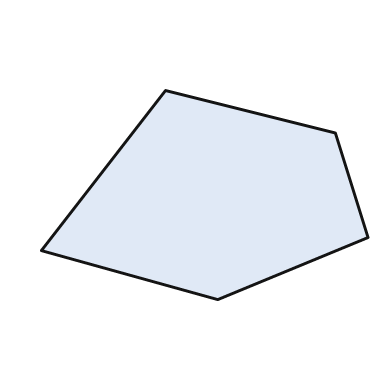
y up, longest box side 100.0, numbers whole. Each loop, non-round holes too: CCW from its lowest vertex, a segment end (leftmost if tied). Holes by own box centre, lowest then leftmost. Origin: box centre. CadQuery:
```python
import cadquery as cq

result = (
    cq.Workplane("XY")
    .moveTo(4.0, -32.0)
    .lineTo(50.0, -13.0)
    .lineTo(40.0, 19.0)
    .lineTo(-12.0, 32.0)
    .lineTo(-50.0, -17.0)
    .close()
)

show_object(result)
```